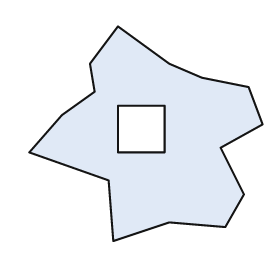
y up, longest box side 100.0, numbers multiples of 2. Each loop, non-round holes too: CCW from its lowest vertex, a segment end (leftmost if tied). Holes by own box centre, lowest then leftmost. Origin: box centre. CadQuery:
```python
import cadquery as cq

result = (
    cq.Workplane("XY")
    .moveTo(-14.0, -46.0)
    .lineTo(10.0, -38.0)
    .lineTo(34.0, -40.0)
    .lineTo(42.0, -26.0)
    .lineTo(32.0, -6.0)
    .lineTo(50.0, 4.0)
    .lineTo(44.0, 20.0)
    .lineTo(24.0, 24.0)
    .lineTo(10.0, 30.0)
    .lineTo(-12.0, 46.0)
    .lineTo(-24.0, 30.0)
    .lineTo(-22.0, 18.0)
    .lineTo(-36.0, 8.0)
    .lineTo(-50.0, -8.0)
    .lineTo(-16.0, -20.0)
    .close()
    .moveTo(-12.0, -8.0)
    .lineTo(8.0, -8.0)
    .lineTo(8.0, 12.0)
    .lineTo(-12.0, 12.0)
    .close()
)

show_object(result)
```